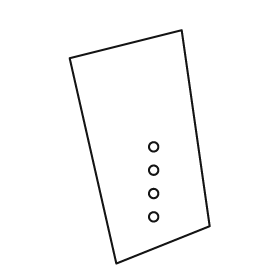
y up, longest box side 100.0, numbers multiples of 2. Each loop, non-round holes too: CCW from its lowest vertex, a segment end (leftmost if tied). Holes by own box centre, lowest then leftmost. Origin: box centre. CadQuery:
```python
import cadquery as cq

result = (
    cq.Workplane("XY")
    .moveTo(-10.0, -50.0)
    .lineTo(30.0, -34.0)
    .lineTo(18.0, 50.0)
    .lineTo(-30.0, 38.0)
    .close()
    .moveTo(6.0, -30.0)
    .circle(2.0)
    .moveTo(6.0, -20.0)
    .circle(2.0)
    .moveTo(6.0, -10.0)
    .circle(2.0)
    .moveTo(6.0, 0.0)
    .circle(2.0)
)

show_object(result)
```